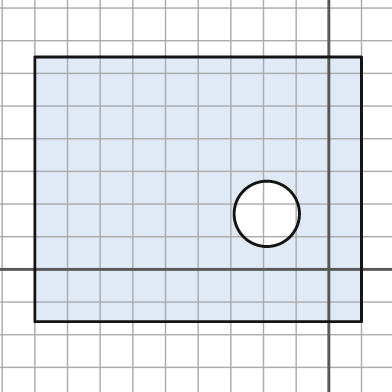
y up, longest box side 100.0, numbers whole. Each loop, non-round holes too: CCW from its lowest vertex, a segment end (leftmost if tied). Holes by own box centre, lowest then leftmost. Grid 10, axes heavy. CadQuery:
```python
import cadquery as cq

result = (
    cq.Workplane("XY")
    .moveTo(-90.0, -16.0)
    .lineTo(10.0, -16.0)
    .lineTo(10.0, 65.0)
    .lineTo(-90.0, 65.0)
    .close()
    .moveTo(-19.0, 17.0)
    .circle(10.0)
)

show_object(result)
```